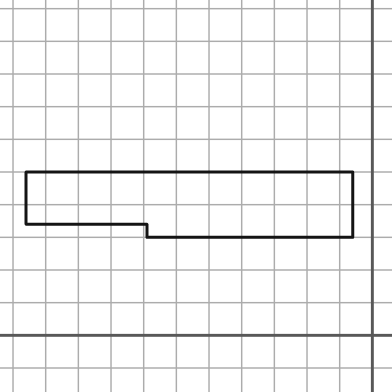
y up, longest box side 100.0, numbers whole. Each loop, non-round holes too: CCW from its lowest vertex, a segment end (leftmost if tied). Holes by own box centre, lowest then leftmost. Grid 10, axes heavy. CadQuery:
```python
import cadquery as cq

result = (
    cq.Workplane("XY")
    .moveTo(-69.0, 30.0)
    .lineTo(-6.0, 30.0)
    .lineTo(-6.0, 50.0)
    .lineTo(-106.0, 50.0)
    .lineTo(-106.0, 34.0)
    .lineTo(-69.0, 34.0)
    .close()
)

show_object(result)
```